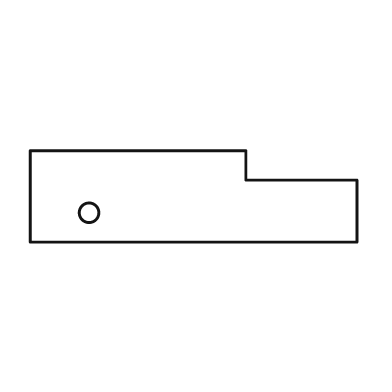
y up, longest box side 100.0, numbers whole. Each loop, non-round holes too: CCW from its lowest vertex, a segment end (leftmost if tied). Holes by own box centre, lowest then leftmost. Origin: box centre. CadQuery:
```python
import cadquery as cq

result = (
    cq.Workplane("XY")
    .moveTo(-50.0, -14.0)
    .lineTo(50.0, -14.0)
    .lineTo(50.0, 5.0)
    .lineTo(16.0, 5.0)
    .lineTo(16.0, 14.0)
    .lineTo(-50.0, 14.0)
    .close()
    .moveTo(-32.0, -5.0)
    .circle(3.0)
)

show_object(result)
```